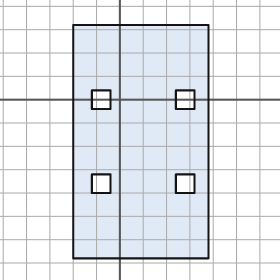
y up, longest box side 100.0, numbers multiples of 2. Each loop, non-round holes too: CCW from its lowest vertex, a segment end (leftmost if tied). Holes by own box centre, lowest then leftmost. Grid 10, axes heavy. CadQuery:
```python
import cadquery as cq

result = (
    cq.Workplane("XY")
    .moveTo(-20.0, -68.0)
    .lineTo(38.0, -68.0)
    .lineTo(38.0, 32.0)
    .lineTo(-20.0, 32.0)
    .close()
    .moveTo(-12.0, -40.0)
    .lineTo(-4.0, -40.0)
    .lineTo(-4.0, -32.0)
    .lineTo(-12.0, -32.0)
    .close()
    .moveTo(24.0, -40.0)
    .lineTo(32.0, -40.0)
    .lineTo(32.0, -32.0)
    .lineTo(24.0, -32.0)
    .close()
    .moveTo(-12.0, -4.0)
    .lineTo(-4.0, -4.0)
    .lineTo(-4.0, 4.0)
    .lineTo(-12.0, 4.0)
    .close()
    .moveTo(24.0, -4.0)
    .lineTo(32.0, -4.0)
    .lineTo(32.0, 4.0)
    .lineTo(24.0, 4.0)
    .close()
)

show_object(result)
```